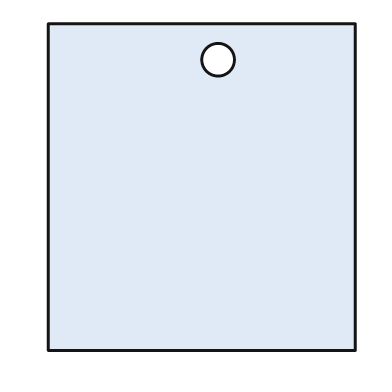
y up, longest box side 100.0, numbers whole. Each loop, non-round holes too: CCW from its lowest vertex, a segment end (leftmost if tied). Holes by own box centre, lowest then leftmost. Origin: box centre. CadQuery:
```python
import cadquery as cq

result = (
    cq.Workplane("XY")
    .moveTo(-47.0, -50.0)
    .lineTo(47.0, -50.0)
    .lineTo(47.0, 50.0)
    .lineTo(-47.0, 50.0)
    .close()
    .moveTo(5.0, 39.0)
    .circle(5.0)
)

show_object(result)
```